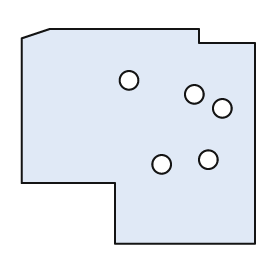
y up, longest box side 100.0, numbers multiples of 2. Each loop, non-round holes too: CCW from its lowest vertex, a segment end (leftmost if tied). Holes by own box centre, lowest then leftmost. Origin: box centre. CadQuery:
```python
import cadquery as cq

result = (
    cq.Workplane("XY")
    .moveTo(-10.0, -46.0)
    .lineTo(50.0, -46.0)
    .lineTo(50.0, 40.0)
    .lineTo(26.0, 40.0)
    .lineTo(26.0, 46.0)
    .lineTo(-38.0, 46.0)
    .lineTo(-50.0, 42.0)
    .lineTo(-50.0, -20.0)
    .lineTo(-10.0, -20.0)
    .close()
    .moveTo(10.0, -12.0)
    .circle(4.0)
    .moveTo(30.0, -10.0)
    .circle(4.0)
    .moveTo(36.0, 12.0)
    .circle(4.0)
    .moveTo(24.0, 18.0)
    .circle(4.0)
    .moveTo(-4.0, 24.0)
    .circle(4.0)
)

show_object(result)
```